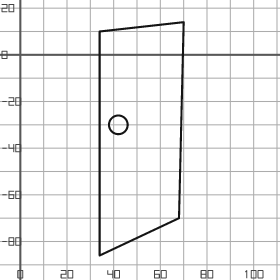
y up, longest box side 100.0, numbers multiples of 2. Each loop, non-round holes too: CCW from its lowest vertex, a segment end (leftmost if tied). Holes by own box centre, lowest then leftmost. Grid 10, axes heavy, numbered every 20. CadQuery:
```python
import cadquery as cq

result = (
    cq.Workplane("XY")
    .moveTo(34.0, -86.0)
    .lineTo(68.0, -70.0)
    .lineTo(70.0, 14.0)
    .lineTo(34.0, 10.0)
    .close()
    .moveTo(42.0, -30.0)
    .circle(4.0)
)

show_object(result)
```